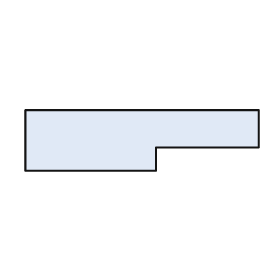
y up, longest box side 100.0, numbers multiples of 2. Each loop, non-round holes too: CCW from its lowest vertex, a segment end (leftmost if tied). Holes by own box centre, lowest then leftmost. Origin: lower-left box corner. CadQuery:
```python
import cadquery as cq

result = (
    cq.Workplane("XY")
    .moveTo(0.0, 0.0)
    .lineTo(56.0, 0.0)
    .lineTo(56.0, 10.0)
    .lineTo(100.0, 10.0)
    .lineTo(100.0, 26.0)
    .lineTo(0.0, 26.0)
    .close()
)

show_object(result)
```